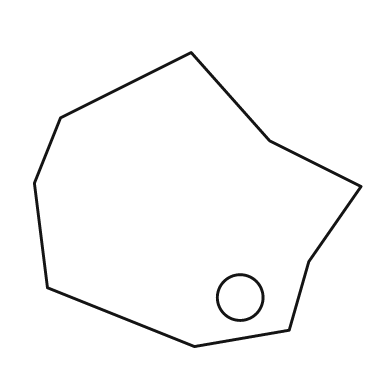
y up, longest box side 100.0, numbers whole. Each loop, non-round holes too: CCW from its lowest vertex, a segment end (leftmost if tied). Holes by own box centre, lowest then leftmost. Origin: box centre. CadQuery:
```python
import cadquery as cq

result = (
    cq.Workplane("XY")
    .moveTo(-1.0, -45.0)
    .lineTo(28.0, -40.0)
    .lineTo(34.0, -19.0)
    .lineTo(50.0, 4.0)
    .lineTo(22.0, 18.0)
    .lineTo(-2.0, 45.0)
    .lineTo(-42.0, 25.0)
    .lineTo(-50.0, 5.0)
    .lineTo(-46.0, -27.0)
    .close()
    .moveTo(13.0, -30.0)
    .circle(7.0)
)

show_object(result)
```